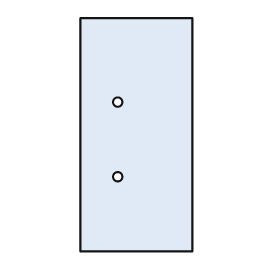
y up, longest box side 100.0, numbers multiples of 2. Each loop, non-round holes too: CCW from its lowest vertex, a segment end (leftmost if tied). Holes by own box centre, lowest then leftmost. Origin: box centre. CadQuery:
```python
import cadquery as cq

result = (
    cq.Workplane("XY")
    .moveTo(-24.0, -50.0)
    .lineTo(24.0, -50.0)
    .lineTo(24.0, 50.0)
    .lineTo(-24.0, 50.0)
    .close()
    .moveTo(-8.0, -18.0)
    .circle(2.0)
    .moveTo(-8.0, 14.0)
    .circle(2.0)
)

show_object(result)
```